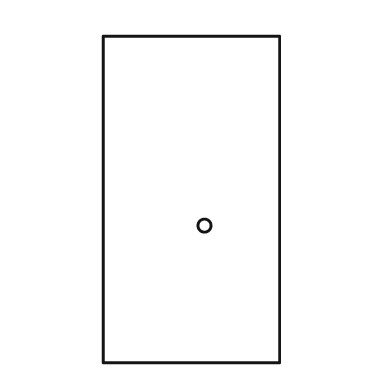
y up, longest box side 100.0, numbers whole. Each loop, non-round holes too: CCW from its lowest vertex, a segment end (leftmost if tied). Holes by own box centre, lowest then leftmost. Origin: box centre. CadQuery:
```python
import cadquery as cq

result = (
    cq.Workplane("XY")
    .moveTo(-27.0, -50.0)
    .lineTo(27.0, -50.0)
    .lineTo(27.0, 50.0)
    .lineTo(-27.0, 50.0)
    .close()
    .moveTo(4.0, -8.0)
    .circle(2.0)
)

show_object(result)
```